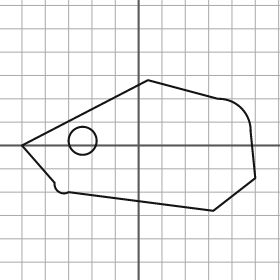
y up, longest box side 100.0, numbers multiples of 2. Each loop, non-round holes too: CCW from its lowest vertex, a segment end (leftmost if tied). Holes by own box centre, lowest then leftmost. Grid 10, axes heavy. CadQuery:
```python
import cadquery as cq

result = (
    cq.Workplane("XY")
    .moveTo(32.0, -28.0)
    .lineTo(50.0, -14.0)
    .lineTo(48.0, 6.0)
    .threePointArc((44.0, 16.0), (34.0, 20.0))
    .lineTo(4.0, 28.0)
    .lineTo(-50.0, 0.0)
    .lineTo(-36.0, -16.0)
    .threePointArc((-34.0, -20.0), (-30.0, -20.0))
    .close()
    .moveTo(-24.0, 2.0)
    .circle(6.0)
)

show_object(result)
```